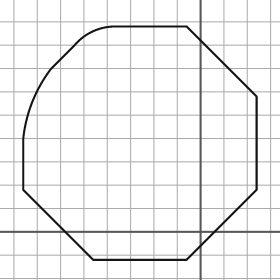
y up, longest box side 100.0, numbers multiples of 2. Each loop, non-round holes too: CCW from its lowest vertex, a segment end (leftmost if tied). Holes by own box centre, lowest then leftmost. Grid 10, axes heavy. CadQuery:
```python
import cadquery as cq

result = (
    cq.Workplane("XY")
    .moveTo(-46.0, -12.0)
    .lineTo(-6.0, -12.0)
    .lineTo(24.0, 18.0)
    .lineTo(24.0, 58.0)
    .lineTo(-6.0, 88.0)
    .lineTo(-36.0, 88.0)
    .threePointArc((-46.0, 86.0), (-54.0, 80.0))
    .lineTo(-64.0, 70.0)
    .threePointArc((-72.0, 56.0), (-76.0, 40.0))
    .lineTo(-76.0, 18.0)
    .close()
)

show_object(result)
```